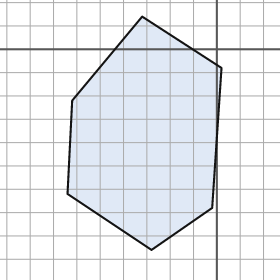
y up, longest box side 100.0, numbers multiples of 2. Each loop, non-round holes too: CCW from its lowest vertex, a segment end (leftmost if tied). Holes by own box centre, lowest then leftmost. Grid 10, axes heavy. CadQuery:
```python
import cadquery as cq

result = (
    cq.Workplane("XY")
    .moveTo(-28.0, -86.0)
    .lineTo(-2.0, -68.0)
    .lineTo(2.0, -8.0)
    .lineTo(-32.0, 14.0)
    .lineTo(-62.0, -22.0)
    .lineTo(-64.0, -62.0)
    .close()
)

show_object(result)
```